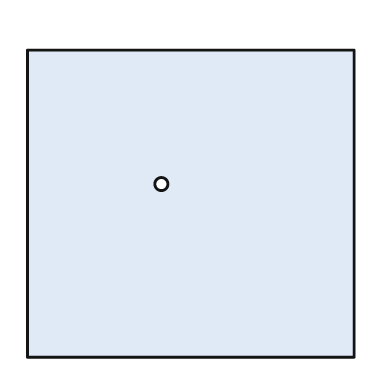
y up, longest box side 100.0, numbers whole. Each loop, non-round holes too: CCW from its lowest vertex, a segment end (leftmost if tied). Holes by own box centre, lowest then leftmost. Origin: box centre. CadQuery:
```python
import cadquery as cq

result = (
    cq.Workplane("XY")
    .moveTo(-50.0, -47.0)
    .lineTo(50.0, -47.0)
    .lineTo(50.0, 47.0)
    .lineTo(-50.0, 47.0)
    .close()
    .moveTo(-9.0, 6.0)
    .circle(2.0)
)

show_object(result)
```